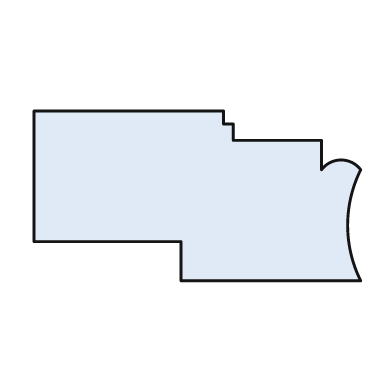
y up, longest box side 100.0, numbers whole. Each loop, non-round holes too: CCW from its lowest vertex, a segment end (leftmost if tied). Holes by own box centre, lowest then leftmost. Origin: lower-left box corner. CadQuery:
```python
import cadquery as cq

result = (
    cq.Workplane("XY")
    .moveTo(45.0, 0.0)
    .lineTo(100.0, 0.0)
    .threePointArc((96.0, 17.0), (100.0, 34.0))
    .threePointArc((94.0, 37.0), (88.0, 34.0))
    .lineTo(88.0, 43.0)
    .lineTo(61.0, 43.0)
    .lineTo(61.0, 48.0)
    .lineTo(58.0, 48.0)
    .lineTo(58.0, 52.0)
    .lineTo(0.0, 52.0)
    .lineTo(0.0, 12.0)
    .lineTo(45.0, 12.0)
    .close()
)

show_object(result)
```